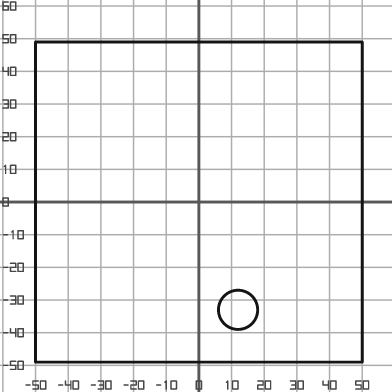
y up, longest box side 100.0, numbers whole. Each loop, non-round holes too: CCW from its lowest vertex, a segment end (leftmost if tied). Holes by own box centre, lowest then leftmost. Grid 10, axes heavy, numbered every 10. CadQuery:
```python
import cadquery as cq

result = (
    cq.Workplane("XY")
    .moveTo(-50.0, -49.0)
    .lineTo(50.0, -49.0)
    .lineTo(50.0, 49.0)
    .lineTo(-50.0, 49.0)
    .close()
    .moveTo(12.0, -33.0)
    .circle(6.0)
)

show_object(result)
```